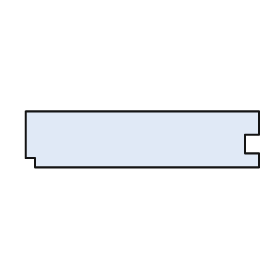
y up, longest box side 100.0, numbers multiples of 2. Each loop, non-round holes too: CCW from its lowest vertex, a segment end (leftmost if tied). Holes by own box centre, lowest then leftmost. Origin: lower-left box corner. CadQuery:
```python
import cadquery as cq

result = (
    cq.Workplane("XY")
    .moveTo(4.0, 0.0)
    .lineTo(100.0, 0.0)
    .lineTo(100.0, 6.0)
    .lineTo(94.0, 6.0)
    .lineTo(94.0, 14.0)
    .lineTo(100.0, 14.0)
    .lineTo(100.0, 24.0)
    .lineTo(0.0, 24.0)
    .lineTo(0.0, 4.0)
    .lineTo(4.0, 4.0)
    .close()
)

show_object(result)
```